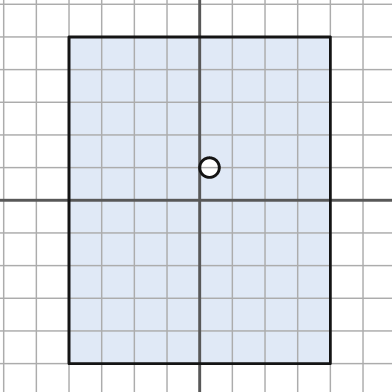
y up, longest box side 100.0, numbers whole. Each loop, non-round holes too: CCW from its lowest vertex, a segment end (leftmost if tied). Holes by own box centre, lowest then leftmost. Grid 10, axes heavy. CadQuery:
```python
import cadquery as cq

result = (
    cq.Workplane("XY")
    .moveTo(-40.0, -50.0)
    .lineTo(40.0, -50.0)
    .lineTo(40.0, 50.0)
    .lineTo(-40.0, 50.0)
    .close()
    .moveTo(3.0, 10.0)
    .circle(3.0)
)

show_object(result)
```